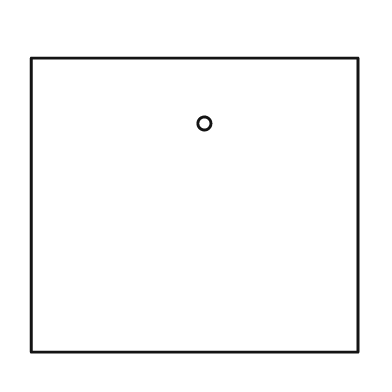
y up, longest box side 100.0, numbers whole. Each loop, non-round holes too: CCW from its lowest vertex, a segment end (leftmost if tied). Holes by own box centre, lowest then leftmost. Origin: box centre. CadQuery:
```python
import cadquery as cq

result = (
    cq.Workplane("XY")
    .moveTo(-50.0, -45.0)
    .lineTo(50.0, -45.0)
    .lineTo(50.0, 45.0)
    .lineTo(-50.0, 45.0)
    .close()
    .moveTo(3.0, 25.0)
    .circle(2.0)
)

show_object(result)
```